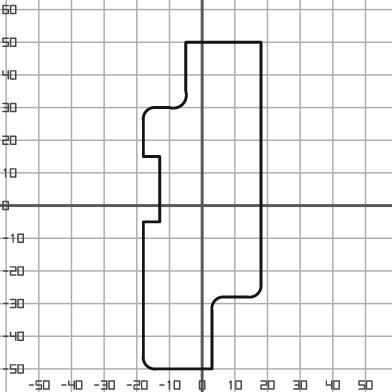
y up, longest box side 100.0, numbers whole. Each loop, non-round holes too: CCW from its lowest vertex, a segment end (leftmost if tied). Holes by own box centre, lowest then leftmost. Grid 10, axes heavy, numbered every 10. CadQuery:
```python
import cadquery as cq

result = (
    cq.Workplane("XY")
    .moveTo(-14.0, -50.0)
    .lineTo(3.0, -50.0)
    .lineTo(3.0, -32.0)
    .threePointArc((4.0, -29.0), (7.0, -28.0))
    .lineTo(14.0, -28.0)
    .threePointArc((17.0, -27.0), (18.0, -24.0))
    .lineTo(18.0, 50.0)
    .lineTo(-5.0, 50.0)
    .lineTo(-5.0, 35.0)
    .threePointArc((-6.0, 31.0), (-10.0, 30.0))
    .lineTo(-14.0, 30.0)
    .threePointArc((-17.0, 29.0), (-18.0, 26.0))
    .lineTo(-18.0, 15.0)
    .lineTo(-13.0, 15.0)
    .lineTo(-13.0, -5.0)
    .lineTo(-18.0, -5.0)
    .lineTo(-18.0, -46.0)
    .threePointArc((-17.0, -49.0), (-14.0, -50.0))
    .close()
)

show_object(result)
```